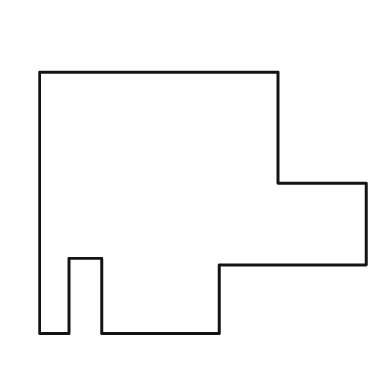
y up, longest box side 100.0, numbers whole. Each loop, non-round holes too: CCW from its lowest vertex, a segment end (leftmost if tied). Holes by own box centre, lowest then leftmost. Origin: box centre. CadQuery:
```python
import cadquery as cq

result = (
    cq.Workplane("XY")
    .moveTo(-50.0, -40.0)
    .lineTo(-41.0, -40.0)
    .lineTo(-41.0, -17.0)
    .lineTo(-31.0, -17.0)
    .lineTo(-31.0, -40.0)
    .lineTo(5.0, -40.0)
    .lineTo(5.0, -19.0)
    .lineTo(50.0, -19.0)
    .lineTo(50.0, 6.0)
    .lineTo(23.0, 6.0)
    .lineTo(23.0, 40.0)
    .lineTo(-50.0, 40.0)
    .close()
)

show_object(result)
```